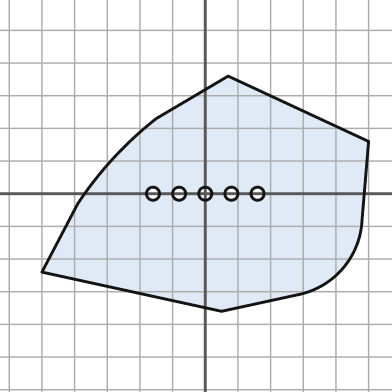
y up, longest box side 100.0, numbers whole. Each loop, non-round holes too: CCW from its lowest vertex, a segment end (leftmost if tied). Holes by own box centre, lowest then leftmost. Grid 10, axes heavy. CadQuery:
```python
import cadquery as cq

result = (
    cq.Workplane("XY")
    .moveTo(5.0, -36.0)
    .lineTo(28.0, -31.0)
    .threePointArc((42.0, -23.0), (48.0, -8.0))
    .lineTo(50.0, 16.0)
    .lineTo(7.0, 36.0)
    .lineTo(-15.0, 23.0)
    .threePointArc((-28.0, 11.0), (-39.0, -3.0))
    .lineTo(-50.0, -24.0)
    .close()
    .moveTo(-16.0, 0.0)
    .circle(2.0)
    .moveTo(-8.0, 0.0)
    .circle(2.0)
    .moveTo(0.0, 0.0)
    .circle(2.0)
    .moveTo(8.0, 0.0)
    .circle(2.0)
    .moveTo(16.0, 0.0)
    .circle(2.0)
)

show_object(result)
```